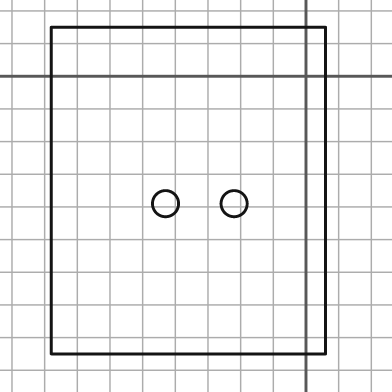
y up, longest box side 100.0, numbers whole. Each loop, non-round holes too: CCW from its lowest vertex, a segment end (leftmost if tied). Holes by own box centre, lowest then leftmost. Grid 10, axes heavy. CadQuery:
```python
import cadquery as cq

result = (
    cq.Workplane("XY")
    .moveTo(-78.0, -85.0)
    .lineTo(6.0, -85.0)
    .lineTo(6.0, 15.0)
    .lineTo(-78.0, 15.0)
    .close()
    .moveTo(-43.0, -39.0)
    .circle(4.0)
    .moveTo(-22.0, -39.0)
    .circle(4.0)
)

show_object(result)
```